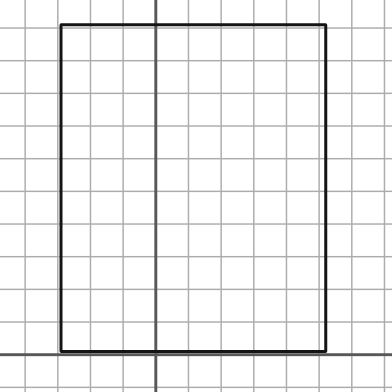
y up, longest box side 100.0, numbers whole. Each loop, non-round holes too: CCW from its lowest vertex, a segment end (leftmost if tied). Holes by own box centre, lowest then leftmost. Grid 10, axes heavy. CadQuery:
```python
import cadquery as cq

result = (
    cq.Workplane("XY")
    .moveTo(-29.0, 1.0)
    .lineTo(52.0, 1.0)
    .lineTo(52.0, 101.0)
    .lineTo(-29.0, 101.0)
    .close()
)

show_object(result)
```